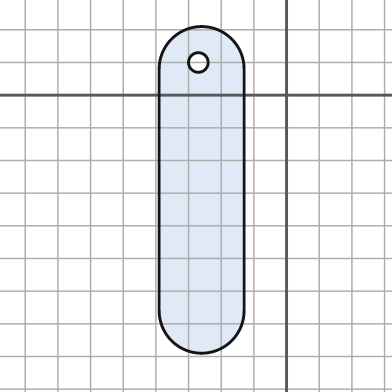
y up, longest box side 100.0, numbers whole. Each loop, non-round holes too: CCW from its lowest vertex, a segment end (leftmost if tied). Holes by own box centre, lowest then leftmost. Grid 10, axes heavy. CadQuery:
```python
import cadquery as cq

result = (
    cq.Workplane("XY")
    .moveTo(-39.0, -66.0)
    .threePointArc((-26.0, -79.0), (-13.0, -66.0))
    .lineTo(-13.0, 8.0)
    .threePointArc((-26.0, 21.0), (-39.0, 8.0))
    .close()
    .moveTo(-27.0, 10.0)
    .circle(3.0)
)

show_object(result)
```